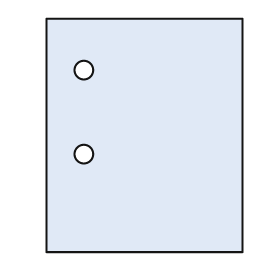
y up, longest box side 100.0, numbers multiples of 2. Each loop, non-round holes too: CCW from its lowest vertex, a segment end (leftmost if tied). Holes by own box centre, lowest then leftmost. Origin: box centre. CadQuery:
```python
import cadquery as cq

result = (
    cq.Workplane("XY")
    .moveTo(-42.0, -50.0)
    .lineTo(42.0, -50.0)
    .lineTo(42.0, 50.0)
    .lineTo(-42.0, 50.0)
    .close()
    .moveTo(-26.0, -8.0)
    .circle(4.0)
    .moveTo(-26.0, 28.0)
    .circle(4.0)
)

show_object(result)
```